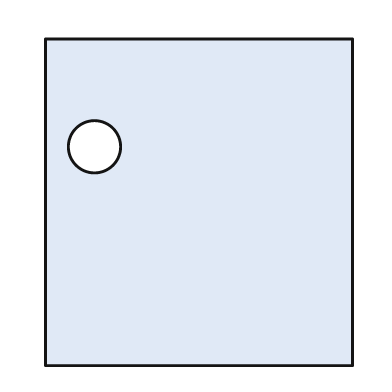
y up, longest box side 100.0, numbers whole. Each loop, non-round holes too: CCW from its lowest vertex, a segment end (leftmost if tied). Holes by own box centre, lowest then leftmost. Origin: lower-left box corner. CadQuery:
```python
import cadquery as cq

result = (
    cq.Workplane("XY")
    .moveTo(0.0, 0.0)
    .lineTo(94.0, 0.0)
    .lineTo(94.0, 100.0)
    .lineTo(0.0, 100.0)
    .close()
    .moveTo(15.0, 67.0)
    .circle(8.0)
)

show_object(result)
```